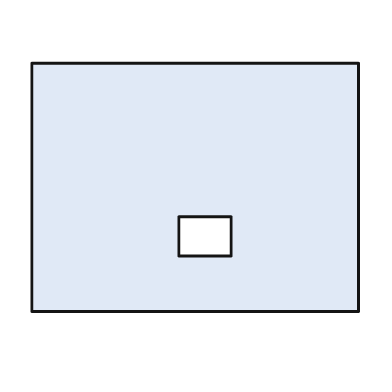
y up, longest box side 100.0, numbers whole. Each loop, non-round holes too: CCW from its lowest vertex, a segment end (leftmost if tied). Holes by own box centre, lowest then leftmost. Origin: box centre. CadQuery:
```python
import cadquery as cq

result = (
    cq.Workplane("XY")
    .moveTo(-50.0, -38.0)
    .lineTo(50.0, -38.0)
    .lineTo(50.0, 38.0)
    .lineTo(-50.0, 38.0)
    .close()
    .moveTo(-5.0, -21.0)
    .lineTo(11.0, -21.0)
    .lineTo(11.0, -9.0)
    .lineTo(-5.0, -9.0)
    .close()
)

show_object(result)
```